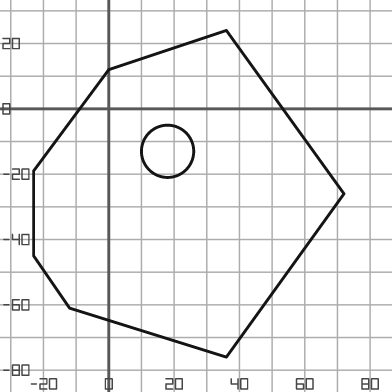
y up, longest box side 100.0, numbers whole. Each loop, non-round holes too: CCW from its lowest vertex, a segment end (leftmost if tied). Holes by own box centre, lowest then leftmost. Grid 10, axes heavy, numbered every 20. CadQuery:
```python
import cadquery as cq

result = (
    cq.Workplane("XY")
    .moveTo(36.0, -76.0)
    .lineTo(72.0, -26.0)
    .lineTo(36.0, 24.0)
    .lineTo(0.0, 12.0)
    .lineTo(-23.0, -19.0)
    .lineTo(-23.0, -45.0)
    .lineTo(-12.0, -61.0)
    .close()
    .moveTo(18.0, -13.0)
    .circle(8.0)
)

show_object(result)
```